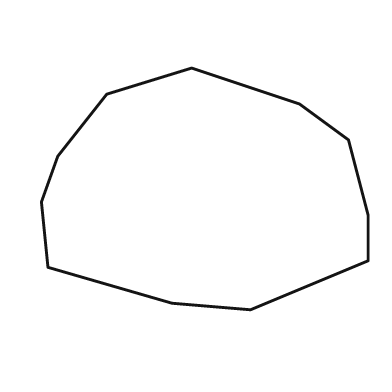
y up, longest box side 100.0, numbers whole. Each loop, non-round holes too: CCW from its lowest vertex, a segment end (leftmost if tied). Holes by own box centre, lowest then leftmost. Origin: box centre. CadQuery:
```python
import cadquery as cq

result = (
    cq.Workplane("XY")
    .moveTo(14.0, -37.0)
    .lineTo(50.0, -22.0)
    .lineTo(50.0, -8.0)
    .lineTo(44.0, 15.0)
    .lineTo(29.0, 26.0)
    .lineTo(-4.0, 37.0)
    .lineTo(-30.0, 29.0)
    .lineTo(-45.0, 10.0)
    .lineTo(-50.0, -4.0)
    .lineTo(-48.0, -24.0)
    .lineTo(-10.0, -35.0)
    .close()
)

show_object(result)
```